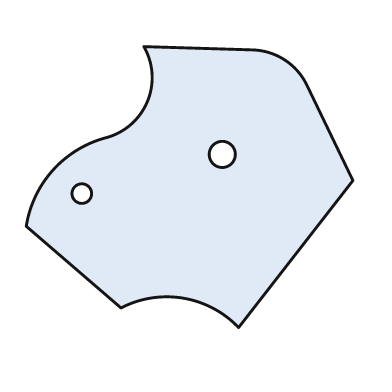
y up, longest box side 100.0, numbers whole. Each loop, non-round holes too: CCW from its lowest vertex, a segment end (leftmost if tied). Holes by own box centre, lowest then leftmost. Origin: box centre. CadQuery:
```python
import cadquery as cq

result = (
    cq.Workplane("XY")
    .moveTo(15.0, -43.0)
    .lineTo(50.0, 2.0)
    .lineTo(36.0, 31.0)
    .threePointArc((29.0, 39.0), (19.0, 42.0))
    .lineTo(-14.0, 43.0)
    .threePointArc((-13.0, 26.0), (-26.0, 15.0))
    .threePointArc((-42.0, 5.0), (-50.0, -12.0))
    .lineTo(-21.0, -37.0)
    .threePointArc((-2.0, -34.0), (15.0, -43.0))
    .close()
    .moveTo(-33.0, -2.0)
    .circle(3.0)
    .moveTo(10.0, 10.0)
    .circle(4.0)
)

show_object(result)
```